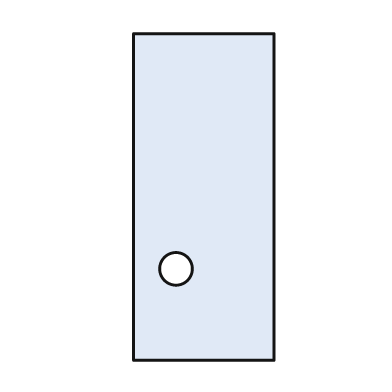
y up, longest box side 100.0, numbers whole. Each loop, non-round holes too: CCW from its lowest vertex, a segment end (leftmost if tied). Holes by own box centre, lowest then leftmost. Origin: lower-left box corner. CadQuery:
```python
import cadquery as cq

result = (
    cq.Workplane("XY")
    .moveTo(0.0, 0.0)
    .lineTo(43.0, 0.0)
    .lineTo(43.0, 100.0)
    .lineTo(0.0, 100.0)
    .close()
    .moveTo(13.0, 28.0)
    .circle(5.0)
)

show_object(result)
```